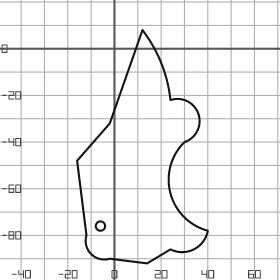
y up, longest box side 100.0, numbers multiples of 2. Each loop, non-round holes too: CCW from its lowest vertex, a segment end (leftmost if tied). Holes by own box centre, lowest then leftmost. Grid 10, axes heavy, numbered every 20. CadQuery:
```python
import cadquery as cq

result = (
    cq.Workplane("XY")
    .moveTo(14.0, -92.0)
    .lineTo(24.0, -86.0)
    .threePointArc((34.0, -86.0), (40.0, -78.0))
    .threePointArc((24.0, -62.0), (30.0, -40.0))
    .threePointArc((36.0, -28.0), (24.0, -22.0))
    .threePointArc((20.0, -6.0), (12.0, 8.0))
    .lineTo(-2.0, -32.0)
    .lineTo(-16.0, -48.0)
    .lineTo(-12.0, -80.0)
    .threePointArc((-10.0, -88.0), (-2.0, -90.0))
    .close()
    .moveTo(-6.0, -76.0)
    .circle(2.0)
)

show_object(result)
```